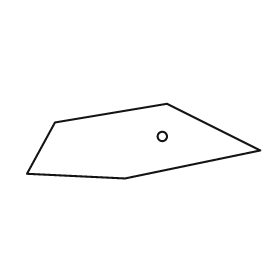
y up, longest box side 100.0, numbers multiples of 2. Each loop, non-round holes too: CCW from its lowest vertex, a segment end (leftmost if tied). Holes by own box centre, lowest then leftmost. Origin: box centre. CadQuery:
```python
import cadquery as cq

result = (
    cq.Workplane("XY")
    .moveTo(-8.0, -16.0)
    .lineTo(50.0, -4.0)
    .lineTo(10.0, 16.0)
    .lineTo(-38.0, 8.0)
    .lineTo(-50.0, -14.0)
    .close()
    .moveTo(8.0, 2.0)
    .circle(2.0)
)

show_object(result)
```